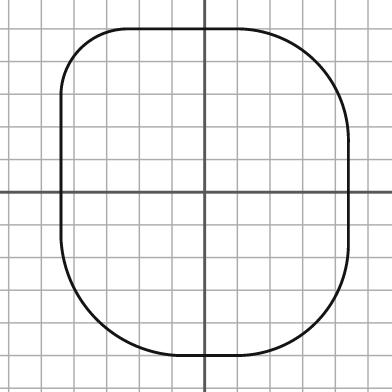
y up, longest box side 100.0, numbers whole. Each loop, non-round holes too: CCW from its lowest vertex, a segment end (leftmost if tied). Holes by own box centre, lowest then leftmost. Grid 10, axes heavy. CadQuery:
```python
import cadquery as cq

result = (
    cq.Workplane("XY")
    .moveTo(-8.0, -50.0)
    .lineTo(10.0, -50.0)
    .threePointArc((34.0, -40.0), (44.0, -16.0))
    .lineTo(44.0, 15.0)
    .threePointArc((34.0, 40.0), (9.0, 50.0))
    .lineTo(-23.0, 50.0)
    .threePointArc((-38.0, 44.0), (-44.0, 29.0))
    .lineTo(-44.0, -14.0)
    .threePointArc((-33.0, -39.0), (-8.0, -50.0))
    .close()
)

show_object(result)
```